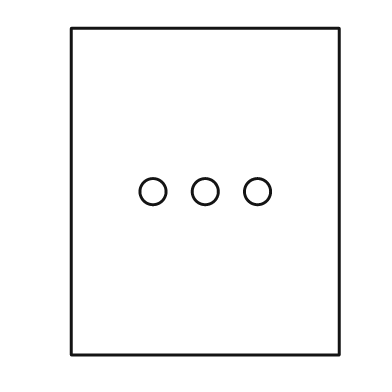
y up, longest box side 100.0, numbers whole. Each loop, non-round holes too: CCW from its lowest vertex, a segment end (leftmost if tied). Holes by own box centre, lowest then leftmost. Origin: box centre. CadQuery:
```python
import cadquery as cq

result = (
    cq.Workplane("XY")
    .moveTo(-41.0, -50.0)
    .lineTo(41.0, -50.0)
    .lineTo(41.0, 50.0)
    .lineTo(-41.0, 50.0)
    .close()
    .moveTo(-16.0, 0.0)
    .circle(4.0)
    .moveTo(0.0, 0.0)
    .circle(4.0)
    .moveTo(16.0, 0.0)
    .circle(4.0)
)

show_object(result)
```